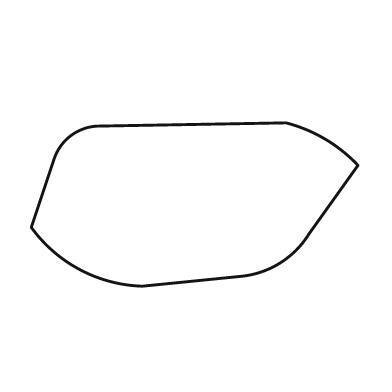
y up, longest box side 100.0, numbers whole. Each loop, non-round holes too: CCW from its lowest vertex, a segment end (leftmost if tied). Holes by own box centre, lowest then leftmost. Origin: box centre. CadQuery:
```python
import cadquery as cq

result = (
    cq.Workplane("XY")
    .moveTo(-16.0, -25.0)
    .lineTo(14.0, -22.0)
    .threePointArc((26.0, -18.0), (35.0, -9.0))
    .lineTo(50.0, 12.0)
    .threePointArc((40.0, 20.0), (28.0, 25.0))
    .lineTo(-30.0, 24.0)
    .threePointArc((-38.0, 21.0), (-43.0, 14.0))
    .lineTo(-50.0, -7.0)
    .threePointArc((-35.0, -20.0), (-16.0, -25.0))
    .close()
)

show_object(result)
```